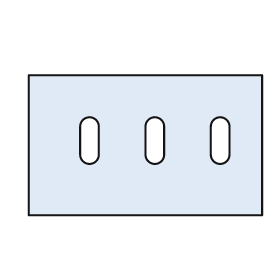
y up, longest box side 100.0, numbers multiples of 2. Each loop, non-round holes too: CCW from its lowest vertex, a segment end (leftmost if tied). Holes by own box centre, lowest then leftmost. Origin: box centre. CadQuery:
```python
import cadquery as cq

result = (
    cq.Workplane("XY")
    .moveTo(-50.0, -30.0)
    .lineTo(50.0, -30.0)
    .lineTo(50.0, 30.0)
    .lineTo(-50.0, 30.0)
    .close()
    .moveTo(-28.0, -4.0)
    .threePointArc((-24.0, -8.0), (-20.0, -4.0))
    .lineTo(-20.0, 8.0)
    .threePointArc((-24.0, 12.0), (-28.0, 8.0))
    .close()
    .moveTo(0.0, -4.0)
    .threePointArc((4.0, -8.0), (8.0, -4.0))
    .lineTo(8.0, 8.0)
    .threePointArc((4.0, 12.0), (0.0, 8.0))
    .close()
    .moveTo(28.0, -4.0)
    .threePointArc((32.0, -8.0), (36.0, -4.0))
    .lineTo(36.0, 8.0)
    .threePointArc((32.0, 12.0), (28.0, 8.0))
    .close()
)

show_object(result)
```